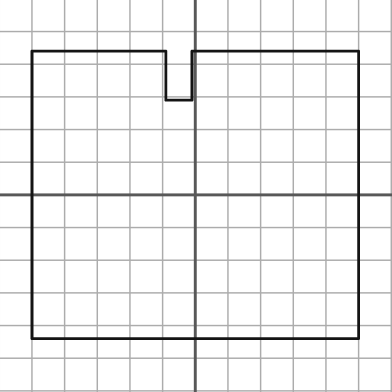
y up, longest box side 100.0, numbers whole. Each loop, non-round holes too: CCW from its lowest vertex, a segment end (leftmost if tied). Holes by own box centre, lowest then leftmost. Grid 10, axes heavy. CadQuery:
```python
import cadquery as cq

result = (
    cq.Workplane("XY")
    .moveTo(-50.0, -44.0)
    .lineTo(50.0, -44.0)
    .lineTo(50.0, 44.0)
    .lineTo(-1.0, 44.0)
    .lineTo(-1.0, 29.0)
    .lineTo(-9.0, 29.0)
    .lineTo(-9.0, 44.0)
    .lineTo(-50.0, 44.0)
    .close()
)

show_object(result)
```